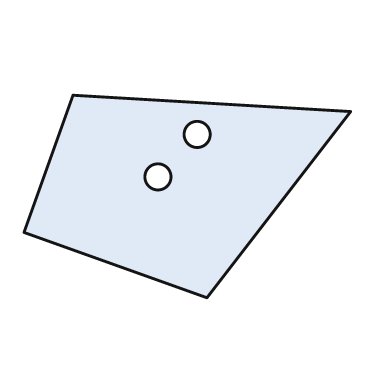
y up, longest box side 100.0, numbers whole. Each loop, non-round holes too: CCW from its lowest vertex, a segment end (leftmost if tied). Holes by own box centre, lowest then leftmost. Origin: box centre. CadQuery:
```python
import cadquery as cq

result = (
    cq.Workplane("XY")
    .moveTo(6.0, -31.0)
    .lineTo(50.0, 26.0)
    .lineTo(-35.0, 31.0)
    .lineTo(-50.0, -11.0)
    .close()
    .moveTo(-9.0, 6.0)
    .circle(4.0)
    .moveTo(3.0, 19.0)
    .circle(4.0)
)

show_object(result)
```